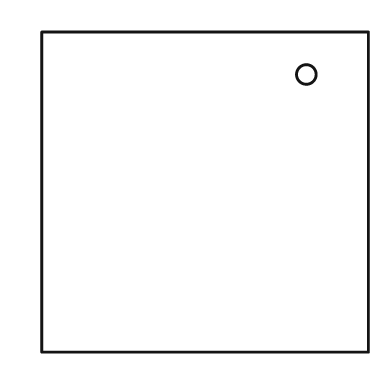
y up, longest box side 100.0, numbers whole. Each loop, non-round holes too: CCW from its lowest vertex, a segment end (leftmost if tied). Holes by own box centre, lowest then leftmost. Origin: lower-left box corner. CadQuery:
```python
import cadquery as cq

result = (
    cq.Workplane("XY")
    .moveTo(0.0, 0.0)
    .lineTo(100.0, 0.0)
    .lineTo(100.0, 98.0)
    .lineTo(0.0, 98.0)
    .close()
    .moveTo(81.0, 85.0)
    .circle(3.0)
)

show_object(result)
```